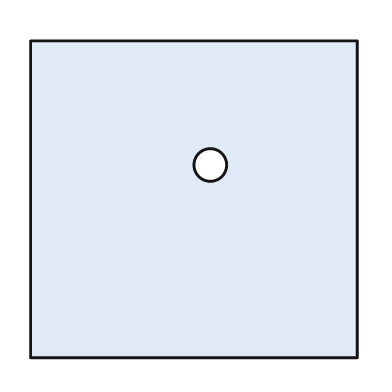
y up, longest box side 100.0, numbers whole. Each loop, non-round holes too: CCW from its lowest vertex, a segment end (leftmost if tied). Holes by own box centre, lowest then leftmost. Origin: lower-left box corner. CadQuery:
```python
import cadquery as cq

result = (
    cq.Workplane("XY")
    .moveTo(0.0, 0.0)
    .lineTo(100.0, 0.0)
    .lineTo(100.0, 97.0)
    .lineTo(0.0, 97.0)
    .close()
    .moveTo(55.0, 59.0)
    .circle(5.0)
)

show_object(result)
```